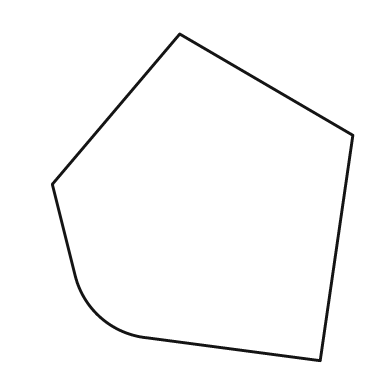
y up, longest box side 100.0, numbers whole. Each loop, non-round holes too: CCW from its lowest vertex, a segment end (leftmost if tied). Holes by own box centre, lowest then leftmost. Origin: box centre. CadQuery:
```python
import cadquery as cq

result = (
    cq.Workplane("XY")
    .moveTo(36.0, -50.0)
    .lineTo(46.0, 19.0)
    .lineTo(-7.0, 50.0)
    .lineTo(-46.0, 4.0)
    .lineTo(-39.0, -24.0)
    .threePointArc((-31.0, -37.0), (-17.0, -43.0))
    .close()
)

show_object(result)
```